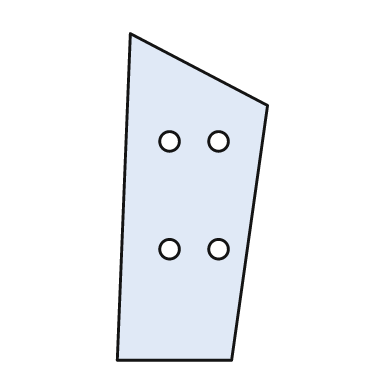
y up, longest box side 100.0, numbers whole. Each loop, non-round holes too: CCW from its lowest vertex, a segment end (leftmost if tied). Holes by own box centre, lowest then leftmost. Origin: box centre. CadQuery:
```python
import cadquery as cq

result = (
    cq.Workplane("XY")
    .moveTo(-23.0, -50.0)
    .lineTo(12.0, -50.0)
    .lineTo(23.0, 28.0)
    .lineTo(-19.0, 50.0)
    .close()
    .moveTo(-7.0, -16.0)
    .circle(3.0)
    .moveTo(8.0, -16.0)
    .circle(3.0)
    .moveTo(-7.0, 17.0)
    .circle(3.0)
    .moveTo(8.0, 17.0)
    .circle(3.0)
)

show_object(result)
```